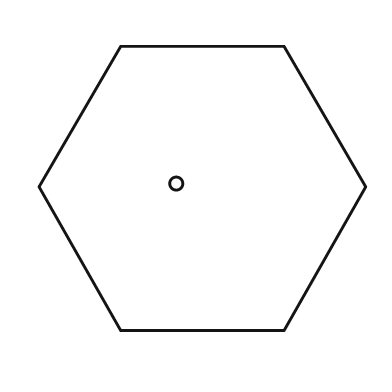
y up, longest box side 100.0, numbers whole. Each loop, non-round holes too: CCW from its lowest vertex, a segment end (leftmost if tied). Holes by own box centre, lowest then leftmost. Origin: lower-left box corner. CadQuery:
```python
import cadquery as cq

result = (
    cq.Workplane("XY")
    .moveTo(25.0, 0.0)
    .lineTo(75.0, 0.0)
    .lineTo(100.0, 44.0)
    .lineTo(75.0, 87.0)
    .lineTo(25.0, 87.0)
    .lineTo(0.0, 44.0)
    .close()
    .moveTo(42.0, 45.0)
    .circle(2.0)
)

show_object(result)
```